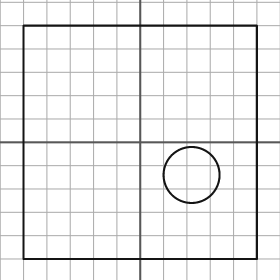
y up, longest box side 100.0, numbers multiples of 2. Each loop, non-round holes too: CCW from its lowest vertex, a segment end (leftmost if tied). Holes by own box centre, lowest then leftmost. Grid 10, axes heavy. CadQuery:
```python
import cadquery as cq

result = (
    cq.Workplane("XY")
    .moveTo(-50.0, -50.0)
    .lineTo(50.0, -50.0)
    .lineTo(50.0, 50.0)
    .lineTo(-50.0, 50.0)
    .close()
    .moveTo(22.0, -14.0)
    .circle(12.0)
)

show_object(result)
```